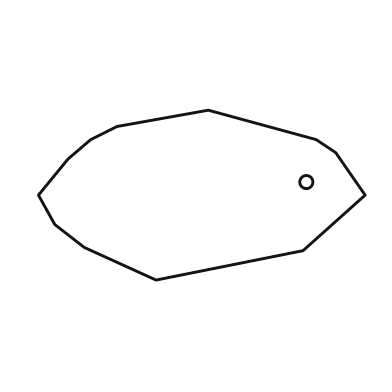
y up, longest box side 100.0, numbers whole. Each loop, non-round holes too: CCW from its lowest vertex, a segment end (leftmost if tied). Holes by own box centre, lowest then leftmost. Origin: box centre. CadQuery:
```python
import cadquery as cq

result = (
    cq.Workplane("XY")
    .moveTo(-14.0, -26.0)
    .lineTo(31.0, -17.0)
    .lineTo(50.0, 0.0)
    .lineTo(41.0, 13.0)
    .lineTo(35.0, 17.0)
    .lineTo(2.0, 26.0)
    .lineTo(-26.0, 21.0)
    .lineTo(-34.0, 17.0)
    .lineTo(-41.0, 11.0)
    .lineTo(-50.0, 0.0)
    .lineTo(-45.0, -9.0)
    .lineTo(-36.0, -16.0)
    .close()
    .moveTo(32.0, 4.0)
    .circle(2.0)
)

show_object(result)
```